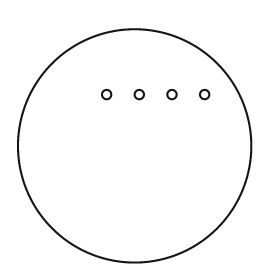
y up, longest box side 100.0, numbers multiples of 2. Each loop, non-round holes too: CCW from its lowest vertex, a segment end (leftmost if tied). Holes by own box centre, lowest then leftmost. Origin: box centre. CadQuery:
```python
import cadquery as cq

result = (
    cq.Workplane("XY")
    .moveTo(0.0, 0.0)
    .circle(50.0)
    .moveTo(-12.0, 22.0)
    .circle(2.0)
    .moveTo(2.0, 22.0)
    .circle(2.0)
    .moveTo(16.0, 22.0)
    .circle(2.0)
    .moveTo(30.0, 22.0)
    .circle(2.0)
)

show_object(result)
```